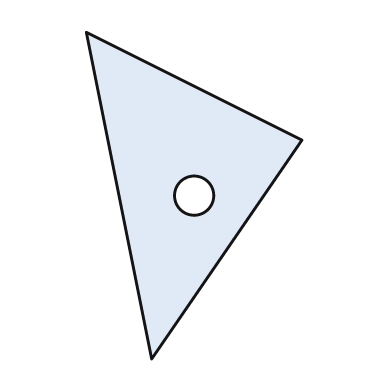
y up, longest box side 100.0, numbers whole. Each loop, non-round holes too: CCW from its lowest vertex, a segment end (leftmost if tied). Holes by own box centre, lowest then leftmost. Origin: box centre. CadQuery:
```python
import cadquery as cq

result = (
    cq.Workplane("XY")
    .moveTo(-13.0, -50.0)
    .lineTo(33.0, 17.0)
    .lineTo(-33.0, 50.0)
    .close()
    .moveTo(0.0, 0.0)
    .circle(6.0)
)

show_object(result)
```